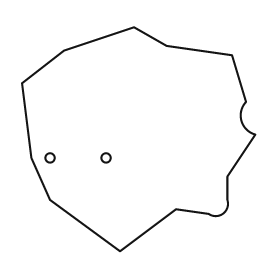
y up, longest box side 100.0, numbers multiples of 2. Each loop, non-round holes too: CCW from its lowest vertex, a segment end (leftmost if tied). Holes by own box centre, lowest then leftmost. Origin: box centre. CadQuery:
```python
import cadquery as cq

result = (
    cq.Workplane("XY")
    .moveTo(-8.0, -48.0)
    .lineTo(16.0, -30.0)
    .lineTo(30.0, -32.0)
    .threePointArc((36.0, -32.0), (38.0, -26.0))
    .lineTo(38.0, -16.0)
    .lineTo(50.0, 2.0)
    .threePointArc((44.0, 8.0), (46.0, 16.0))
    .lineTo(40.0, 36.0)
    .lineTo(12.0, 40.0)
    .lineTo(-2.0, 48.0)
    .lineTo(-32.0, 38.0)
    .lineTo(-50.0, 24.0)
    .lineTo(-46.0, -8.0)
    .lineTo(-38.0, -26.0)
    .close()
    .moveTo(-38.0, -8.0)
    .circle(2.0)
    .moveTo(-14.0, -8.0)
    .circle(2.0)
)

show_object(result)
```